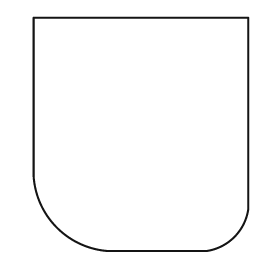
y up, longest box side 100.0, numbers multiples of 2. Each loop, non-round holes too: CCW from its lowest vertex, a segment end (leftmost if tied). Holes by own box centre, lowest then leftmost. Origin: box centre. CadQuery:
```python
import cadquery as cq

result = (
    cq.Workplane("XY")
    .moveTo(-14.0, -50.0)
    .lineTo(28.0, -50.0)
    .threePointArc((40.0, -44.0), (46.0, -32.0))
    .lineTo(46.0, 50.0)
    .lineTo(-46.0, 50.0)
    .lineTo(-46.0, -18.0)
    .threePointArc((-36.0, -40.0), (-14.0, -50.0))
    .close()
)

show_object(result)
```